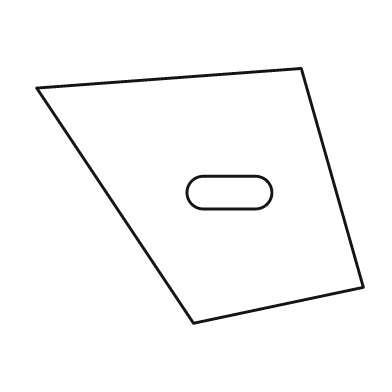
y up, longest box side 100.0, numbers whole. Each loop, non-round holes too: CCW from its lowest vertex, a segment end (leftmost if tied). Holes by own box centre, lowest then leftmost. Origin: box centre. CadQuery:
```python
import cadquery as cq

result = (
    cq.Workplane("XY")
    .moveTo(-2.0, -39.0)
    .lineTo(50.0, -28.0)
    .lineTo(31.0, 39.0)
    .lineTo(-50.0, 33.0)
    .close()
    .moveTo(1.0, -4.0)
    .lineTo(17.0, -4.0)
    .threePointArc((22.0, 1.0), (17.0, 6.0))
    .lineTo(1.0, 6.0)
    .threePointArc((-4.0, 1.0), (1.0, -4.0))
    .close()
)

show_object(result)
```